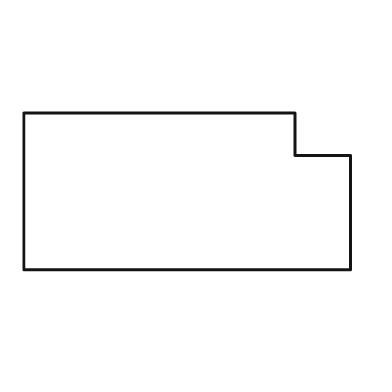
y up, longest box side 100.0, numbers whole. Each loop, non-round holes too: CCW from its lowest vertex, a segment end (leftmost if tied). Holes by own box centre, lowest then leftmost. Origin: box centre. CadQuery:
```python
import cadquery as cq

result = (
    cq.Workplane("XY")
    .moveTo(-50.0, -24.0)
    .lineTo(50.0, -24.0)
    .lineTo(50.0, 11.0)
    .lineTo(33.0, 11.0)
    .lineTo(33.0, 24.0)
    .lineTo(-50.0, 24.0)
    .close()
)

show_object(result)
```